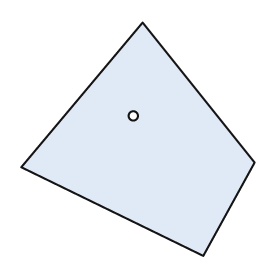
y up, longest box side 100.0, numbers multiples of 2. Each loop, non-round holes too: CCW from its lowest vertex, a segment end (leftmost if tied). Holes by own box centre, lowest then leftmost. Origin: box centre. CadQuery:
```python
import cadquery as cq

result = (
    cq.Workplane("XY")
    .moveTo(28.0, -50.0)
    .lineTo(50.0, -10.0)
    .lineTo(2.0, 50.0)
    .lineTo(-50.0, -12.0)
    .close()
    .moveTo(-2.0, 10.0)
    .circle(2.0)
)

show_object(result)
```